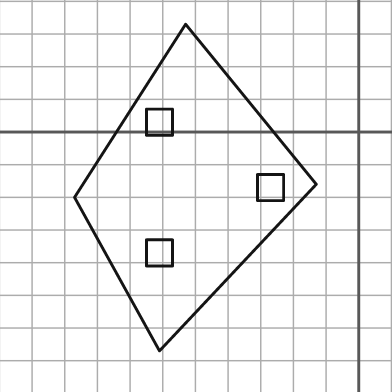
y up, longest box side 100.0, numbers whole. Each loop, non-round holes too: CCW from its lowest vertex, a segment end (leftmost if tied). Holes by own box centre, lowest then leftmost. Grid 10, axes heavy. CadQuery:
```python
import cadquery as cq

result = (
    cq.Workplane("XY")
    .moveTo(-61.0, -67.0)
    .lineTo(-13.0, -16.0)
    .lineTo(-53.0, 33.0)
    .lineTo(-87.0, -20.0)
    .close()
    .moveTo(-65.0, -41.0)
    .lineTo(-57.0, -41.0)
    .lineTo(-57.0, -33.0)
    .lineTo(-65.0, -33.0)
    .close()
    .moveTo(-31.0, -21.0)
    .lineTo(-23.0, -21.0)
    .lineTo(-23.0, -13.0)
    .lineTo(-31.0, -13.0)
    .close()
    .moveTo(-65.0, -1.0)
    .lineTo(-57.0, -1.0)
    .lineTo(-57.0, 7.0)
    .lineTo(-65.0, 7.0)
    .close()
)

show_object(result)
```